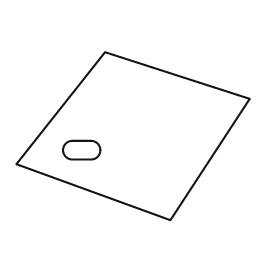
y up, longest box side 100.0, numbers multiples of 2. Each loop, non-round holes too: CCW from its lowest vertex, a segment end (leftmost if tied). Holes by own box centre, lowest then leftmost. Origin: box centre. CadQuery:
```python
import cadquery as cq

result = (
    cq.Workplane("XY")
    .moveTo(16.0, -36.0)
    .lineTo(50.0, 16.0)
    .lineTo(-12.0, 36.0)
    .lineTo(-50.0, -12.0)
    .close()
    .moveTo(-26.0, -10.0)
    .lineTo(-18.0, -10.0)
    .threePointArc((-14.0, -6.0), (-18.0, -2.0))
    .lineTo(-26.0, -2.0)
    .threePointArc((-30.0, -6.0), (-26.0, -10.0))
    .close()
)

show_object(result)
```